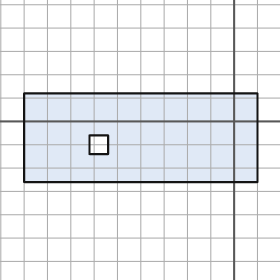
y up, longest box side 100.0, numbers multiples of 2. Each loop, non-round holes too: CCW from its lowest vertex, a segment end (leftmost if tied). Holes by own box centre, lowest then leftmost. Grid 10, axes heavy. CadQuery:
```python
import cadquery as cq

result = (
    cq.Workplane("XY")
    .moveTo(-90.0, -26.0)
    .lineTo(10.0, -26.0)
    .lineTo(10.0, 12.0)
    .lineTo(-90.0, 12.0)
    .close()
    .moveTo(-62.0, -14.0)
    .lineTo(-54.0, -14.0)
    .lineTo(-54.0, -6.0)
    .lineTo(-62.0, -6.0)
    .close()
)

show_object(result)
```